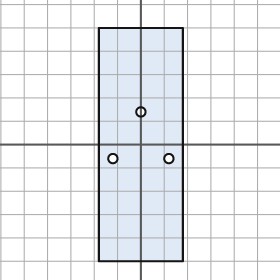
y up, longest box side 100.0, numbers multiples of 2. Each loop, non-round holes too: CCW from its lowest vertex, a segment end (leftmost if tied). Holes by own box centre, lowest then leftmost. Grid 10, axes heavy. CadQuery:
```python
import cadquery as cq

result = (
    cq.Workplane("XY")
    .moveTo(-18.0, -50.0)
    .lineTo(18.0, -50.0)
    .lineTo(18.0, 50.0)
    .lineTo(-18.0, 50.0)
    .close()
    .moveTo(-12.0, -6.0)
    .circle(2.0)
    .moveTo(12.0, -6.0)
    .circle(2.0)
    .moveTo(0.0, 14.0)
    .circle(2.0)
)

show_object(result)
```